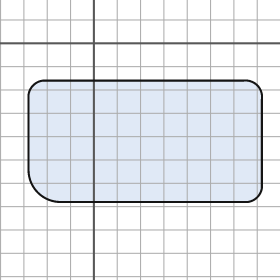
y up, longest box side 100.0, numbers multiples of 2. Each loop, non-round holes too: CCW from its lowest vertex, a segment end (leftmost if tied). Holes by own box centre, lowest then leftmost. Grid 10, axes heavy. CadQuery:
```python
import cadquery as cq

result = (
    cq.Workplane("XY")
    .moveTo(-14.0, -68.0)
    .lineTo(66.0, -68.0)
    .threePointArc((70.0, -66.0), (72.0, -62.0))
    .lineTo(72.0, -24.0)
    .threePointArc((70.0, -18.0), (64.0, -16.0))
    .lineTo(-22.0, -16.0)
    .threePointArc((-26.0, -18.0), (-28.0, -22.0))
    .lineTo(-28.0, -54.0)
    .threePointArc((-24.0, -64.0), (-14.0, -68.0))
    .close()
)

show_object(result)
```